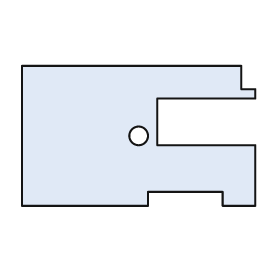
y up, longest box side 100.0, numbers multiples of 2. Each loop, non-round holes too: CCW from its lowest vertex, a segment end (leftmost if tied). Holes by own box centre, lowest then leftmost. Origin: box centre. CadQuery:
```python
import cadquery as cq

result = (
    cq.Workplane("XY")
    .moveTo(-50.0, -30.0)
    .lineTo(4.0, -30.0)
    .lineTo(4.0, -24.0)
    .lineTo(36.0, -24.0)
    .lineTo(36.0, -30.0)
    .lineTo(50.0, -30.0)
    .lineTo(50.0, -4.0)
    .lineTo(8.0, -4.0)
    .lineTo(8.0, 16.0)
    .lineTo(50.0, 16.0)
    .lineTo(50.0, 20.0)
    .lineTo(44.0, 20.0)
    .lineTo(44.0, 30.0)
    .lineTo(-50.0, 30.0)
    .close()
    .moveTo(0.0, 0.0)
    .circle(4.0)
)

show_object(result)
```